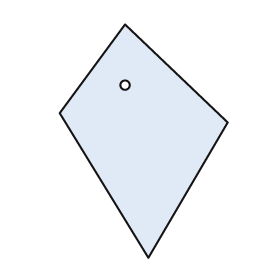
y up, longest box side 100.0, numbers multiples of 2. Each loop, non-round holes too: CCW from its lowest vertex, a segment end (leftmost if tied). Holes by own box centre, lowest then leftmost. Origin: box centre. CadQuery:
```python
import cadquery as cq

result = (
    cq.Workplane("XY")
    .moveTo(2.0, -50.0)
    .lineTo(36.0, 8.0)
    .lineTo(-8.0, 50.0)
    .lineTo(-36.0, 12.0)
    .close()
    .moveTo(-8.0, 24.0)
    .circle(2.0)
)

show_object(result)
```